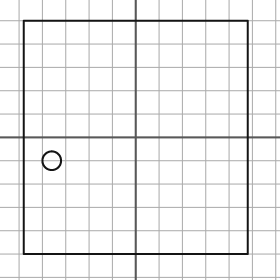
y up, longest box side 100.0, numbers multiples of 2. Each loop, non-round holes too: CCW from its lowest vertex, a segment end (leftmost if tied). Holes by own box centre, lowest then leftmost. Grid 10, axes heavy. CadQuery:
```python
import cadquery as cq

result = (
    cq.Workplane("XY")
    .moveTo(-48.0, -50.0)
    .lineTo(48.0, -50.0)
    .lineTo(48.0, 50.0)
    .lineTo(-48.0, 50.0)
    .close()
    .moveTo(-36.0, -10.0)
    .circle(4.0)
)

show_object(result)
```